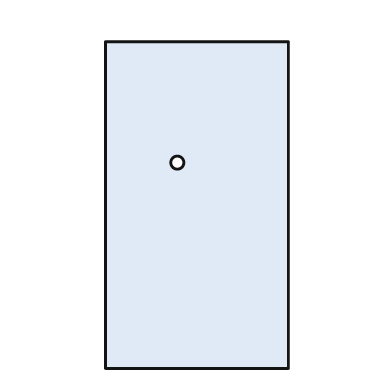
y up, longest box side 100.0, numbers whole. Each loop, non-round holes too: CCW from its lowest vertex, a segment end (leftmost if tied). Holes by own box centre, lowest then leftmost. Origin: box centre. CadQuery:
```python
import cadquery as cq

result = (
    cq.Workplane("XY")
    .moveTo(-28.0, -50.0)
    .lineTo(28.0, -50.0)
    .lineTo(28.0, 50.0)
    .lineTo(-28.0, 50.0)
    .close()
    .moveTo(-6.0, 13.0)
    .circle(2.0)
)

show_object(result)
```